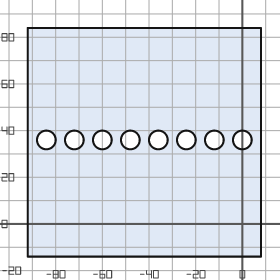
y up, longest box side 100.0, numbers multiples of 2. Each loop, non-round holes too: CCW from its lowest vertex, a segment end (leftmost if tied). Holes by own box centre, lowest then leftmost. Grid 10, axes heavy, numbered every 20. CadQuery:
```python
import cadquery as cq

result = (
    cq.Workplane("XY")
    .moveTo(-92.0, -14.0)
    .lineTo(8.0, -14.0)
    .lineTo(8.0, 84.0)
    .lineTo(-92.0, 84.0)
    .close()
    .moveTo(-84.0, 36.0)
    .circle(4.0)
    .moveTo(-72.0, 36.0)
    .circle(4.0)
    .moveTo(-60.0, 36.0)
    .circle(4.0)
    .moveTo(-48.0, 36.0)
    .circle(4.0)
    .moveTo(-36.0, 36.0)
    .circle(4.0)
    .moveTo(-24.0, 36.0)
    .circle(4.0)
    .moveTo(-12.0, 36.0)
    .circle(4.0)
    .moveTo(0.0, 36.0)
    .circle(4.0)
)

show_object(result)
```